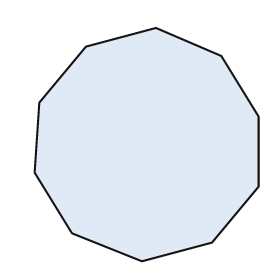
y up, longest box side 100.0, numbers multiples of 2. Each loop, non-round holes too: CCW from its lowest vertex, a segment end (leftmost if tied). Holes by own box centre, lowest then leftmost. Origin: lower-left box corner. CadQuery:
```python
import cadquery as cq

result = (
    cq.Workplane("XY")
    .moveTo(46.0, 0.0)
    .lineTo(76.0, 8.0)
    .lineTo(96.0, 32.0)
    .lineTo(96.0, 62.0)
    .lineTo(80.0, 88.0)
    .lineTo(52.0, 100.0)
    .lineTo(22.0, 92.0)
    .lineTo(2.0, 68.0)
    .lineTo(0.0, 38.0)
    .lineTo(16.0, 12.0)
    .close()
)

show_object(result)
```